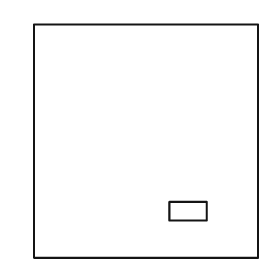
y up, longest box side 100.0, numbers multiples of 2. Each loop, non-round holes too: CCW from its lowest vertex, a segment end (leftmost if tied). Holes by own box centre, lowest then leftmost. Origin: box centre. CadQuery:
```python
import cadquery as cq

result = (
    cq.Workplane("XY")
    .moveTo(-48.0, -50.0)
    .lineTo(48.0, -50.0)
    .lineTo(48.0, 50.0)
    .lineTo(-48.0, 50.0)
    .close()
    .moveTo(10.0, -34.0)
    .lineTo(26.0, -34.0)
    .lineTo(26.0, -26.0)
    .lineTo(10.0, -26.0)
    .close()
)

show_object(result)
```